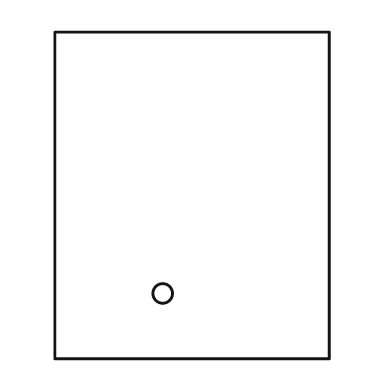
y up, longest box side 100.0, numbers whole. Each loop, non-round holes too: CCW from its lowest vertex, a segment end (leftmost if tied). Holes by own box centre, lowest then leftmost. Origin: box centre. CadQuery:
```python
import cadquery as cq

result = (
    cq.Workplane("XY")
    .moveTo(-42.0, -50.0)
    .lineTo(42.0, -50.0)
    .lineTo(42.0, 50.0)
    .lineTo(-42.0, 50.0)
    .close()
    .moveTo(-9.0, -30.0)
    .circle(3.0)
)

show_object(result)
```